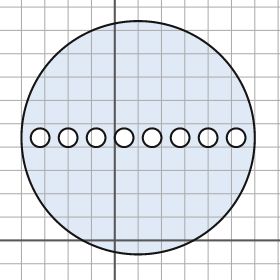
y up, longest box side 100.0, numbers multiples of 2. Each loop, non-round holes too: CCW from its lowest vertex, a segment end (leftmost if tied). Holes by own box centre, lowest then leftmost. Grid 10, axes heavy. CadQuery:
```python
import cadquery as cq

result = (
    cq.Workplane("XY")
    .moveTo(10.0, 44.0)
    .circle(50.0)
    .moveTo(-32.0, 44.0)
    .circle(4.0)
    .moveTo(-20.0, 44.0)
    .circle(4.0)
    .moveTo(-8.0, 44.0)
    .circle(4.0)
    .moveTo(4.0, 44.0)
    .circle(4.0)
    .moveTo(16.0, 44.0)
    .circle(4.0)
    .moveTo(28.0, 44.0)
    .circle(4.0)
    .moveTo(40.0, 44.0)
    .circle(4.0)
    .moveTo(52.0, 44.0)
    .circle(4.0)
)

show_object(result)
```